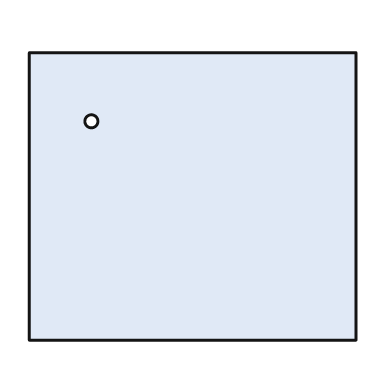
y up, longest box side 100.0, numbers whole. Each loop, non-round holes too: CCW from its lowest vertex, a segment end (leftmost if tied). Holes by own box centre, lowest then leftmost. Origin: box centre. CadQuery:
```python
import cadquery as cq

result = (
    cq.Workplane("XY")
    .moveTo(-50.0, -44.0)
    .lineTo(50.0, -44.0)
    .lineTo(50.0, 44.0)
    .lineTo(-50.0, 44.0)
    .close()
    .moveTo(-31.0, 23.0)
    .circle(2.0)
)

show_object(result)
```